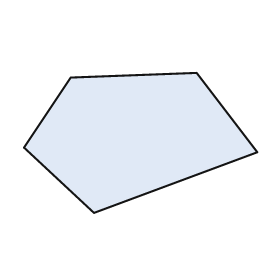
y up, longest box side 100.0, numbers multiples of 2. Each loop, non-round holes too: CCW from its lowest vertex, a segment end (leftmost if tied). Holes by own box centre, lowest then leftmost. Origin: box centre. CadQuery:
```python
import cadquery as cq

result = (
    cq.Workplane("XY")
    .moveTo(-20.0, -30.0)
    .lineTo(50.0, -4.0)
    .lineTo(24.0, 30.0)
    .lineTo(-30.0, 28.0)
    .lineTo(-50.0, -2.0)
    .close()
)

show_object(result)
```